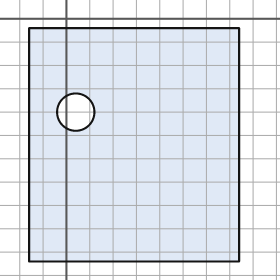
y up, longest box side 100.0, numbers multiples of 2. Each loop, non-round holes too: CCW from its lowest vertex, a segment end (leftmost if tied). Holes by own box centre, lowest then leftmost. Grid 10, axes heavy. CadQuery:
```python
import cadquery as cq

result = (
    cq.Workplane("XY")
    .moveTo(-16.0, -104.0)
    .lineTo(74.0, -104.0)
    .lineTo(74.0, -4.0)
    .lineTo(-16.0, -4.0)
    .close()
    .moveTo(4.0, -40.0)
    .circle(8.0)
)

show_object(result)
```